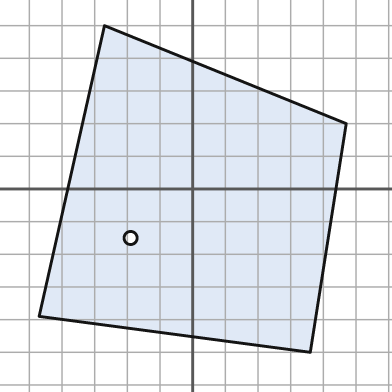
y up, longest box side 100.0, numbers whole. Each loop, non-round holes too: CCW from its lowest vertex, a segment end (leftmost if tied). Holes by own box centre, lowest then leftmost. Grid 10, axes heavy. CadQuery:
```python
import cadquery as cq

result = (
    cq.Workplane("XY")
    .moveTo(36.0, -50.0)
    .lineTo(47.0, 20.0)
    .lineTo(-27.0, 50.0)
    .lineTo(-47.0, -39.0)
    .close()
    .moveTo(-19.0, -15.0)
    .circle(2.0)
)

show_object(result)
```